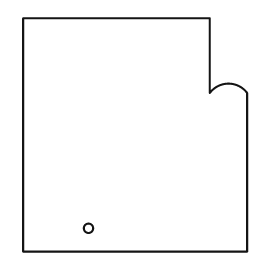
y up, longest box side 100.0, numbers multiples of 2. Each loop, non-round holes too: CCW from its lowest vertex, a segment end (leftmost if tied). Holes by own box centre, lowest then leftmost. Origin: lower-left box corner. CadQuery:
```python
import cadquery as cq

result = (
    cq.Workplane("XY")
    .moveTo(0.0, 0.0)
    .lineTo(96.0, 0.0)
    .lineTo(96.0, 68.0)
    .threePointArc((88.0, 72.0), (80.0, 68.0))
    .lineTo(80.0, 100.0)
    .lineTo(0.0, 100.0)
    .close()
    .moveTo(28.0, 10.0)
    .circle(2.0)
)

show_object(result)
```